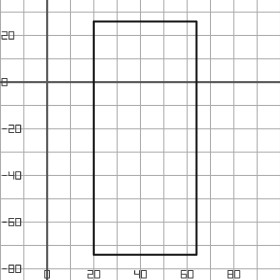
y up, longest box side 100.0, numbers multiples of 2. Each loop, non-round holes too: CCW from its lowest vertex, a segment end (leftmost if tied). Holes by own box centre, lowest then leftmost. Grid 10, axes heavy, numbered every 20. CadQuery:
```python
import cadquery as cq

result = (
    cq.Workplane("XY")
    .moveTo(20.0, -74.0)
    .lineTo(64.0, -74.0)
    .lineTo(64.0, 26.0)
    .lineTo(20.0, 26.0)
    .close()
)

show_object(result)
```